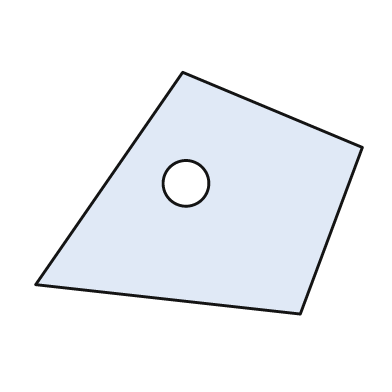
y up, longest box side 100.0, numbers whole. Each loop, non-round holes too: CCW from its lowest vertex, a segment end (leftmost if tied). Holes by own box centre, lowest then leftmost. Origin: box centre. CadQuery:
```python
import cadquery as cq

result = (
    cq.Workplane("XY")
    .moveTo(31.0, -37.0)
    .lineTo(50.0, 14.0)
    .lineTo(-5.0, 37.0)
    .lineTo(-50.0, -28.0)
    .close()
    .moveTo(-4.0, 3.0)
    .circle(7.0)
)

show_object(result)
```